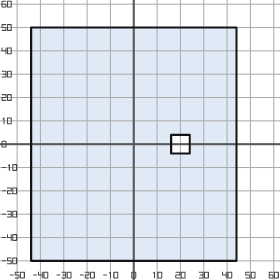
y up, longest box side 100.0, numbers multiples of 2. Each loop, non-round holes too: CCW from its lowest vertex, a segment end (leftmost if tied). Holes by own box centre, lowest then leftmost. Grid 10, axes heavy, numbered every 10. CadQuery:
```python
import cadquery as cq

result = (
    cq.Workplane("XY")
    .moveTo(-44.0, -50.0)
    .lineTo(44.0, -50.0)
    .lineTo(44.0, 50.0)
    .lineTo(-44.0, 50.0)
    .close()
    .moveTo(16.0, -4.0)
    .lineTo(24.0, -4.0)
    .lineTo(24.0, 4.0)
    .lineTo(16.0, 4.0)
    .close()
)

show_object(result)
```